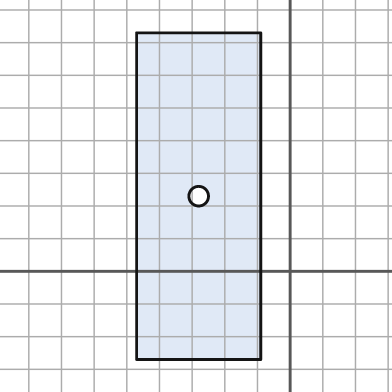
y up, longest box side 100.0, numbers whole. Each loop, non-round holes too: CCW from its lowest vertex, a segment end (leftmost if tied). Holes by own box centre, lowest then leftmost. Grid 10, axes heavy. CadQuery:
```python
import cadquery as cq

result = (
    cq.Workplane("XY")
    .moveTo(-47.0, -27.0)
    .lineTo(-9.0, -27.0)
    .lineTo(-9.0, 73.0)
    .lineTo(-47.0, 73.0)
    .close()
    .moveTo(-28.0, 23.0)
    .circle(3.0)
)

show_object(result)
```